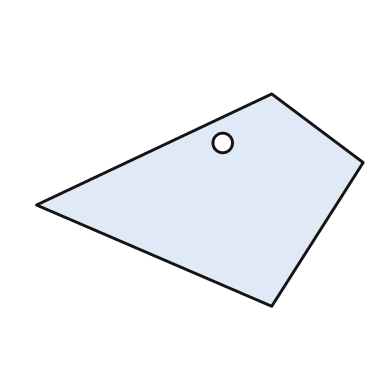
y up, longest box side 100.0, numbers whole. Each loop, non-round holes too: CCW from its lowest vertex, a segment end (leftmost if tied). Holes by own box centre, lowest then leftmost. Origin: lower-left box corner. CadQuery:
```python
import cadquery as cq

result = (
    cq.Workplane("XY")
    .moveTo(72.0, 0.0)
    .lineTo(100.0, 44.0)
    .lineTo(72.0, 65.0)
    .lineTo(0.0, 31.0)
    .close()
    .moveTo(57.0, 50.0)
    .circle(3.0)
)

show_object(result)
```